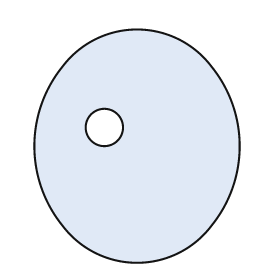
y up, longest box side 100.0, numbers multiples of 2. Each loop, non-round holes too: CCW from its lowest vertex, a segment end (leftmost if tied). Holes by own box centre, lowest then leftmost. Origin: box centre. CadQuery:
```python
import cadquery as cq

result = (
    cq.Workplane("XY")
    .moveTo(-32.0, -34.0)
    .threePointArc((0.0, -50.0), (32.0, -34.0))
    .threePointArc((44.0, 0.0), (32.0, 34.0))
    .threePointArc((0.0, 50.0), (-32.0, 34.0))
    .threePointArc((-44.0, 0.0), (-32.0, -34.0))
    .close()
    .moveTo(-14.0, 8.0)
    .circle(8.0)
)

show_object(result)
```